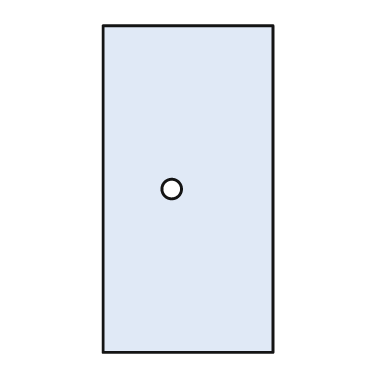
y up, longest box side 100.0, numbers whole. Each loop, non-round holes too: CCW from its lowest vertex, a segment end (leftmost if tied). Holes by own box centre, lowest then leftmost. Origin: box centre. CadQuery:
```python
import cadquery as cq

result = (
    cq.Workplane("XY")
    .moveTo(-26.0, -50.0)
    .lineTo(26.0, -50.0)
    .lineTo(26.0, 50.0)
    .lineTo(-26.0, 50.0)
    .close()
    .moveTo(-5.0, 0.0)
    .circle(3.0)
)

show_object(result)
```